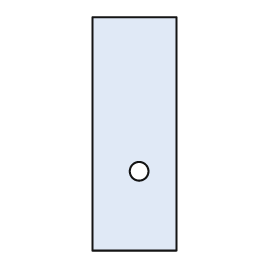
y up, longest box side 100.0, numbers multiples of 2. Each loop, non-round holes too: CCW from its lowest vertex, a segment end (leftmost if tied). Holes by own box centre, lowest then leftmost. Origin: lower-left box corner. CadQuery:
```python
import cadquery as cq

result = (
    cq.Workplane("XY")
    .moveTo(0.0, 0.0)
    .lineTo(36.0, 0.0)
    .lineTo(36.0, 100.0)
    .lineTo(0.0, 100.0)
    .close()
    .moveTo(20.0, 34.0)
    .circle(4.0)
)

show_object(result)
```